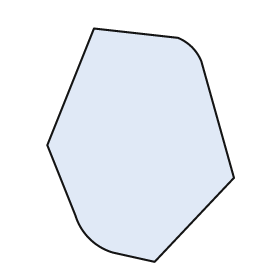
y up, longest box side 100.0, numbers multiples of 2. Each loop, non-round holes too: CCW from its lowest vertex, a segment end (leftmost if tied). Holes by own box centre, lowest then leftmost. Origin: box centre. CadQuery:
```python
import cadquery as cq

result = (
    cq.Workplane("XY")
    .moveTo(6.0, -50.0)
    .lineTo(40.0, -14.0)
    .lineTo(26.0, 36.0)
    .threePointArc((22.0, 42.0), (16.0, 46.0))
    .lineTo(-20.0, 50.0)
    .lineTo(-40.0, 0.0)
    .lineTo(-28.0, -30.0)
    .threePointArc((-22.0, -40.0), (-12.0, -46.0))
    .close()
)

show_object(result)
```